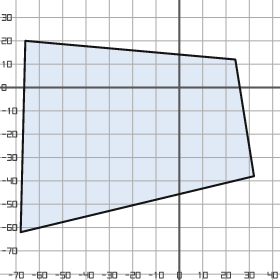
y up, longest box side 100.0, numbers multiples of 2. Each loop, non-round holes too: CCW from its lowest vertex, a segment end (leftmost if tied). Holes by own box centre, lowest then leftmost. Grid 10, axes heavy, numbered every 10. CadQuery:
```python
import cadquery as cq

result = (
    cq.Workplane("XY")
    .moveTo(-68.0, -62.0)
    .lineTo(32.0, -38.0)
    .lineTo(24.0, 12.0)
    .lineTo(-66.0, 20.0)
    .close()
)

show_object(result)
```